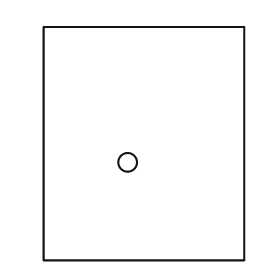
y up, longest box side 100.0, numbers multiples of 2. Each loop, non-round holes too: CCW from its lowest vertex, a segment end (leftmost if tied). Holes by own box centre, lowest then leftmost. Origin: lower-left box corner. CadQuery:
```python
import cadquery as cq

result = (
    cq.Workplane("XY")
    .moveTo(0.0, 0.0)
    .lineTo(86.0, 0.0)
    .lineTo(86.0, 100.0)
    .lineTo(0.0, 100.0)
    .close()
    .moveTo(36.0, 42.0)
    .circle(4.0)
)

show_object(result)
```